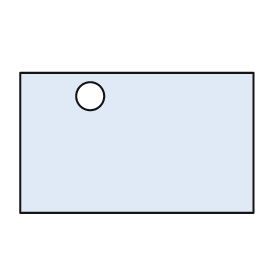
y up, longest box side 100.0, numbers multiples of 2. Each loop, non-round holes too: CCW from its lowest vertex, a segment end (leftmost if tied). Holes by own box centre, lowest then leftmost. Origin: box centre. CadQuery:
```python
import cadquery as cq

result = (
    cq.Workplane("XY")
    .moveTo(-50.0, -30.0)
    .lineTo(50.0, -30.0)
    .lineTo(50.0, 30.0)
    .lineTo(-50.0, 30.0)
    .close()
    .moveTo(-20.0, 20.0)
    .circle(6.0)
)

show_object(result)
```